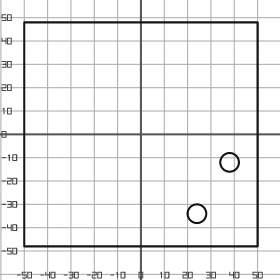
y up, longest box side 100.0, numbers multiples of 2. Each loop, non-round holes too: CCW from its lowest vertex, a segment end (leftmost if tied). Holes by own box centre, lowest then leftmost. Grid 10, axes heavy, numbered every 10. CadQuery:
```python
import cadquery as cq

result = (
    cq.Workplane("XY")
    .moveTo(-50.0, -48.0)
    .lineTo(50.0, -48.0)
    .lineTo(50.0, 48.0)
    .lineTo(-50.0, 48.0)
    .close()
    .moveTo(24.0, -34.0)
    .circle(4.0)
    .moveTo(38.0, -12.0)
    .circle(4.0)
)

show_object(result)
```